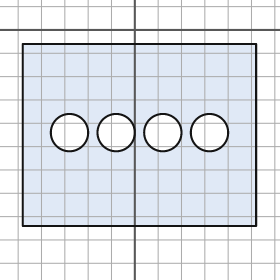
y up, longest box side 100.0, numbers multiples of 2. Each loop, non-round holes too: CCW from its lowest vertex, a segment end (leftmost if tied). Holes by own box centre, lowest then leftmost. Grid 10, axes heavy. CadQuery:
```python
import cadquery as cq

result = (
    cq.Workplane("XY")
    .moveTo(-48.0, -84.0)
    .lineTo(52.0, -84.0)
    .lineTo(52.0, -6.0)
    .lineTo(-48.0, -6.0)
    .close()
    .moveTo(-28.0, -44.0)
    .circle(8.0)
    .moveTo(-8.0, -44.0)
    .circle(8.0)
    .moveTo(12.0, -44.0)
    .circle(8.0)
    .moveTo(32.0, -44.0)
    .circle(8.0)
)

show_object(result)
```